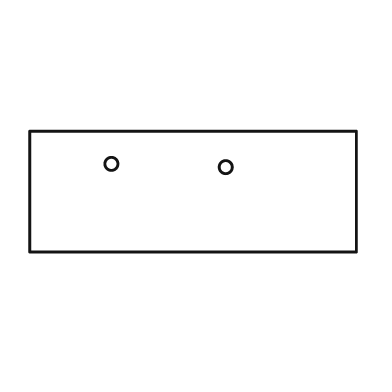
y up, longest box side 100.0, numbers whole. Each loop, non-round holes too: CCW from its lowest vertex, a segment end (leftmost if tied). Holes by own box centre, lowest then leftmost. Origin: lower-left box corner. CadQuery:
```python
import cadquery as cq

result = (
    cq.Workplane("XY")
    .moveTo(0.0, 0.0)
    .lineTo(100.0, 0.0)
    .lineTo(100.0, 37.0)
    .lineTo(0.0, 37.0)
    .close()
    .moveTo(60.0, 26.0)
    .circle(2.0)
    .moveTo(25.0, 27.0)
    .circle(2.0)
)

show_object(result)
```